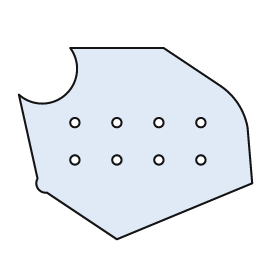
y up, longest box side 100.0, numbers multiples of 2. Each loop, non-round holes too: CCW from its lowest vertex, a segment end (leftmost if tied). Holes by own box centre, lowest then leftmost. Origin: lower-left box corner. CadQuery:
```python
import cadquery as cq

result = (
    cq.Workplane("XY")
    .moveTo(42.0, 0.0)
    .lineTo(100.0, 24.0)
    .lineTo(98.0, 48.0)
    .threePointArc((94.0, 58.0), (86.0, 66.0))
    .lineTo(62.0, 82.0)
    .lineTo(22.0, 82.0)
    .threePointArc((20.0, 62.0), (0.0, 62.0))
    .lineTo(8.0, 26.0)
    .threePointArc((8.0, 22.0), (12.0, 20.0))
    .close()
    .moveTo(24.0, 34.0)
    .circle(2.0)
    .moveTo(42.0, 34.0)
    .circle(2.0)
    .moveTo(60.0, 34.0)
    .circle(2.0)
    .moveTo(78.0, 34.0)
    .circle(2.0)
    .moveTo(24.0, 50.0)
    .circle(2.0)
    .moveTo(42.0, 50.0)
    .circle(2.0)
    .moveTo(60.0, 50.0)
    .circle(2.0)
    .moveTo(78.0, 50.0)
    .circle(2.0)
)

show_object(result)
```